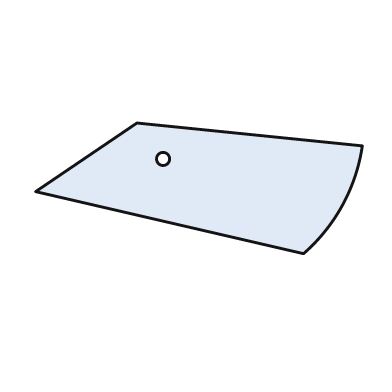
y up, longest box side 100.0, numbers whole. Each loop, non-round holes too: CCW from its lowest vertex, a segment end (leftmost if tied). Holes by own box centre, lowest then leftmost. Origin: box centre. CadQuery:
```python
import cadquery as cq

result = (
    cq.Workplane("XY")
    .moveTo(32.0, -20.0)
    .threePointArc((44.0, -5.0), (50.0, 13.0))
    .lineTo(-19.0, 20.0)
    .lineTo(-50.0, -1.0)
    .close()
    .moveTo(-11.0, 9.0)
    .circle(2.0)
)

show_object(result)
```